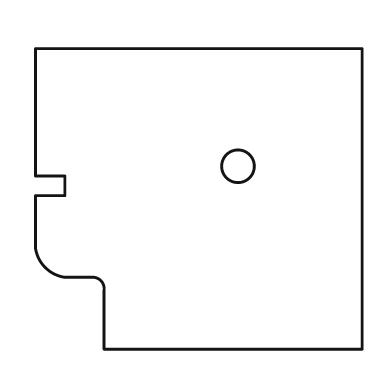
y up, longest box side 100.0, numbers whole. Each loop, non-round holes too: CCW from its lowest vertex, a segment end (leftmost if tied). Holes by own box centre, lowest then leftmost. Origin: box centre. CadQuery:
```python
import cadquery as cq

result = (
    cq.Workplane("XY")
    .moveTo(-29.0, -46.0)
    .lineTo(50.0, -46.0)
    .lineTo(50.0, 46.0)
    .lineTo(-50.0, 46.0)
    .lineTo(-50.0, 7.0)
    .lineTo(-41.0, 7.0)
    .lineTo(-41.0, 1.0)
    .lineTo(-50.0, 1.0)
    .lineTo(-50.0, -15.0)
    .threePointArc((-47.0, -21.0), (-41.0, -24.0))
    .lineTo(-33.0, -24.0)
    .threePointArc((-30.0, -25.0), (-29.0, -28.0))
    .close()
    .moveTo(12.0, 10.0)
    .circle(5.0)
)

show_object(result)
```